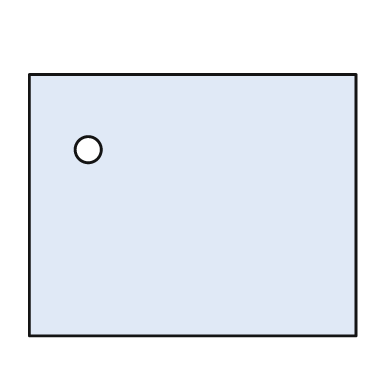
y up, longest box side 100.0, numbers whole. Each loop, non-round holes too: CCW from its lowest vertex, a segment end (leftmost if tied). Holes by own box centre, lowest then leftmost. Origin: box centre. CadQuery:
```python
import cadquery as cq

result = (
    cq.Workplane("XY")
    .moveTo(-50.0, -40.0)
    .lineTo(50.0, -40.0)
    .lineTo(50.0, 40.0)
    .lineTo(-50.0, 40.0)
    .close()
    .moveTo(-32.0, 17.0)
    .circle(4.0)
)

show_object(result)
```